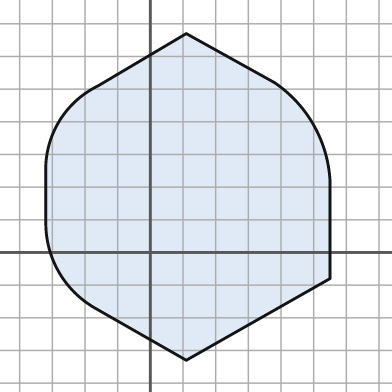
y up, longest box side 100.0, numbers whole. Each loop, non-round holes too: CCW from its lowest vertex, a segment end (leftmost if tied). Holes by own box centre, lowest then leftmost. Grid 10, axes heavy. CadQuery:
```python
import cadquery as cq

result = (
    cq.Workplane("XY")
    .moveTo(11.0, -33.0)
    .lineTo(55.0, -8.0)
    .lineTo(55.0, 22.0)
    .threePointArc((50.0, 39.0), (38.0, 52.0))
    .lineTo(11.0, 67.0)
    .lineTo(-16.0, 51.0)
    .threePointArc((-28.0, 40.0), (-32.0, 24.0))
    .lineTo(-32.0, 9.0)
    .threePointArc((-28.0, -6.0), (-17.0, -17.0))
    .close()
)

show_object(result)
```